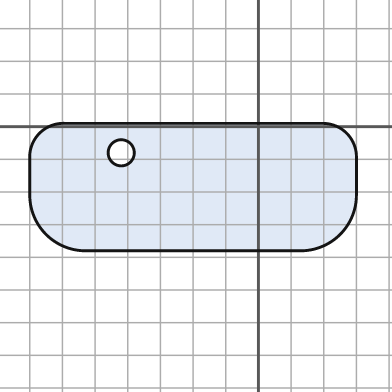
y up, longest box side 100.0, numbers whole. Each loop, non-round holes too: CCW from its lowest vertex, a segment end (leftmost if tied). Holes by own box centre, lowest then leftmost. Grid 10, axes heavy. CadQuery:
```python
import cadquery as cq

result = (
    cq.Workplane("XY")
    .moveTo(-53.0, -38.0)
    .lineTo(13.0, -38.0)
    .threePointArc((25.0, -33.0), (30.0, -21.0))
    .lineTo(30.0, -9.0)
    .threePointArc((27.0, -2.0), (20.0, 1.0))
    .lineTo(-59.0, 1.0)
    .threePointArc((-67.0, -2.0), (-70.0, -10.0))
    .lineTo(-70.0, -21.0)
    .threePointArc((-65.0, -33.0), (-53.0, -38.0))
    .close()
    .moveTo(-42.0, -8.0)
    .circle(4.0)
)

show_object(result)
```